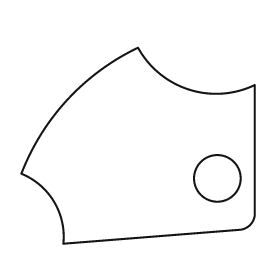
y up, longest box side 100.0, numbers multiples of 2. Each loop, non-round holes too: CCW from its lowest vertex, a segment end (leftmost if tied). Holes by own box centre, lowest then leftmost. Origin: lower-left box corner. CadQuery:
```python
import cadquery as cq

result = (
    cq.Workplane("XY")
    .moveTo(18.0, 0.0)
    .lineTo(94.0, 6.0)
    .threePointArc((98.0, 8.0), (100.0, 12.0))
    .lineTo(100.0, 68.0)
    .threePointArc((72.0, 66.0), (50.0, 84.0))
    .threePointArc((20.0, 62.0), (0.0, 30.0))
    .threePointArc((14.0, 18.0), (18.0, 0.0))
    .close()
    .moveTo(84.0, 28.0)
    .circle(10.0)
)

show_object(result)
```